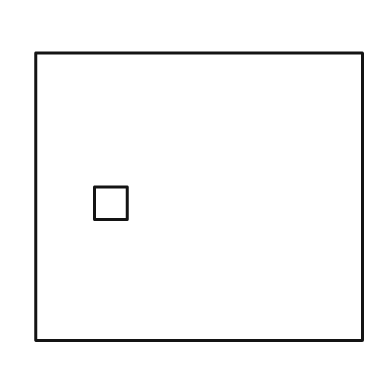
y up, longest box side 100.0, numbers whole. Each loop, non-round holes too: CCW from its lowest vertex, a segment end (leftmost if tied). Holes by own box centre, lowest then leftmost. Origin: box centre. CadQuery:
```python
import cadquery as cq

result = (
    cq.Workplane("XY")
    .moveTo(-50.0, -44.0)
    .lineTo(50.0, -44.0)
    .lineTo(50.0, 44.0)
    .lineTo(-50.0, 44.0)
    .close()
    .moveTo(-32.0, -7.0)
    .lineTo(-22.0, -7.0)
    .lineTo(-22.0, 3.0)
    .lineTo(-32.0, 3.0)
    .close()
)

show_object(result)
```